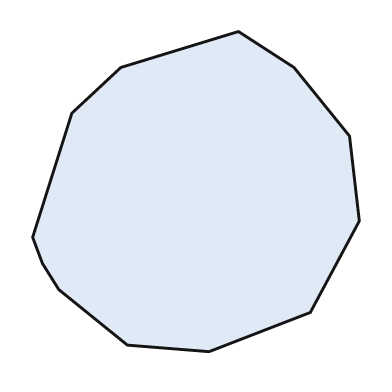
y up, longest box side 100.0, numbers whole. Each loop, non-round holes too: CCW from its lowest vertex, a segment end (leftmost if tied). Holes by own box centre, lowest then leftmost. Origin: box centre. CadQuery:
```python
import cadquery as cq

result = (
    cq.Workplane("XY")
    .moveTo(4.0, -49.0)
    .lineTo(35.0, -37.0)
    .lineTo(50.0, -9.0)
    .lineTo(47.0, 17.0)
    .lineTo(30.0, 38.0)
    .lineTo(13.0, 49.0)
    .lineTo(-23.0, 38.0)
    .lineTo(-38.0, 24.0)
    .lineTo(-50.0, -14.0)
    .lineTo(-47.0, -22.0)
    .lineTo(-42.0, -30.0)
    .lineTo(-21.0, -47.0)
    .close()
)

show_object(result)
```